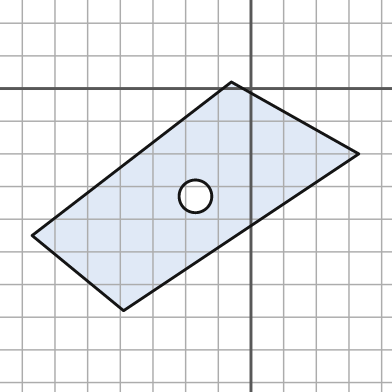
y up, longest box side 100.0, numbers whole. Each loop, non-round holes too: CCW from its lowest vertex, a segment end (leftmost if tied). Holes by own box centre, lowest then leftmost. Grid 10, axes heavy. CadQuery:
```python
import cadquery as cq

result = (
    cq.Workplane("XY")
    .moveTo(-39.0, -68.0)
    .lineTo(33.0, -20.0)
    .lineTo(-6.0, 2.0)
    .lineTo(-67.0, -45.0)
    .close()
    .moveTo(-17.0, -33.0)
    .circle(5.0)
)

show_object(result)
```